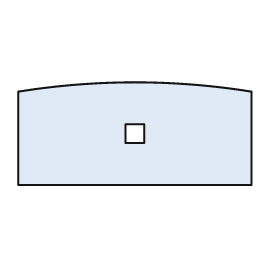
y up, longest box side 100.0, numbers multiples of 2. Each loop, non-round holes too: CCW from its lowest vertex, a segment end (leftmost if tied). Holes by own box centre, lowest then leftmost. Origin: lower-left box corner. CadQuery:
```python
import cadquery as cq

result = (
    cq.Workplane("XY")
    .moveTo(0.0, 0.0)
    .lineTo(100.0, 0.0)
    .lineTo(100.0, 40.0)
    .threePointArc((50.0, 44.0), (0.0, 40.0))
    .close()
    .moveTo(46.0, 18.0)
    .lineTo(54.0, 18.0)
    .lineTo(54.0, 26.0)
    .lineTo(46.0, 26.0)
    .close()
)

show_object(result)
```